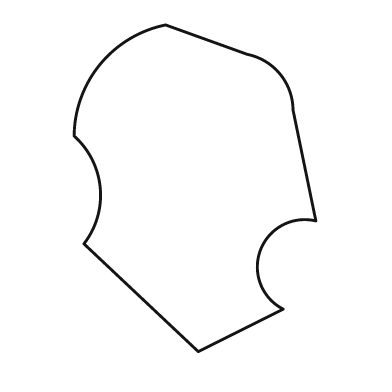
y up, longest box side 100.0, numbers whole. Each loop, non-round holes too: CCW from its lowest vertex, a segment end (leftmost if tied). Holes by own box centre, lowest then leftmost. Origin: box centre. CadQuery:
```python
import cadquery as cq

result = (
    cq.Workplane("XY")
    .moveTo(1.0, -50.0)
    .lineTo(27.0, -37.0)
    .threePointArc((20.0, -19.0), (37.0, -10.0))
    .lineTo(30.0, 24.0)
    .threePointArc((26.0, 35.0), (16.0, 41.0))
    .lineTo(-9.0, 50.0)
    .threePointArc((-29.0, 38.0), (-37.0, 16.0))
    .threePointArc((-29.0, 0.0), (-34.0, -17.0))
    .close()
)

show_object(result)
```